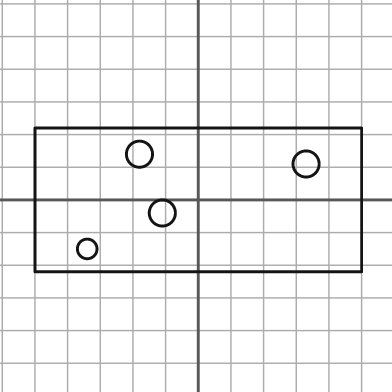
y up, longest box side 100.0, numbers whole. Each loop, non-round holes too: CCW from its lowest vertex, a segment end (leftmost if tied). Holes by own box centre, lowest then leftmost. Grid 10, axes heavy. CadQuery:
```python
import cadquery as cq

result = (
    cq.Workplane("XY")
    .moveTo(-50.0, -22.0)
    .lineTo(50.0, -22.0)
    .lineTo(50.0, 22.0)
    .lineTo(-50.0, 22.0)
    .close()
    .moveTo(-34.0, -15.0)
    .circle(3.0)
    .moveTo(-11.0, -4.0)
    .circle(4.0)
    .moveTo(33.0, 11.0)
    .circle(4.0)
    .moveTo(-18.0, 14.0)
    .circle(4.0)
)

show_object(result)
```